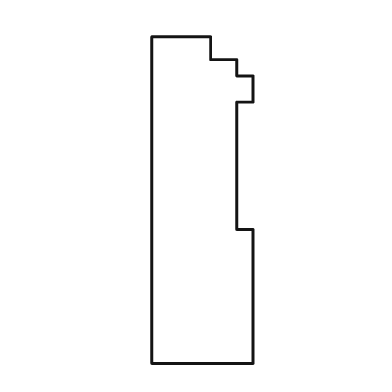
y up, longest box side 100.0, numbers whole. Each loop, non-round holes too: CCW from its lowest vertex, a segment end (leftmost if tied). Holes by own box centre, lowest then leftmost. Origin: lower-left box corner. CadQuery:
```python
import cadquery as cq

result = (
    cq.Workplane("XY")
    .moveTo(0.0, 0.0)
    .lineTo(31.0, 0.0)
    .lineTo(31.0, 41.0)
    .lineTo(26.0, 41.0)
    .lineTo(26.0, 80.0)
    .lineTo(31.0, 80.0)
    .lineTo(31.0, 88.0)
    .lineTo(26.0, 88.0)
    .lineTo(26.0, 93.0)
    .lineTo(18.0, 93.0)
    .lineTo(18.0, 100.0)
    .lineTo(0.0, 100.0)
    .close()
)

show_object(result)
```